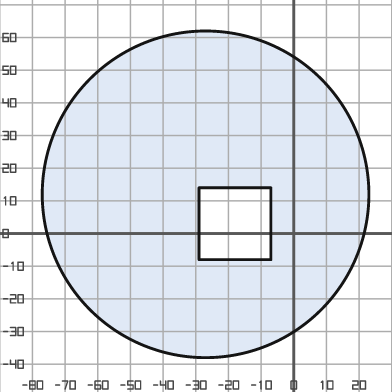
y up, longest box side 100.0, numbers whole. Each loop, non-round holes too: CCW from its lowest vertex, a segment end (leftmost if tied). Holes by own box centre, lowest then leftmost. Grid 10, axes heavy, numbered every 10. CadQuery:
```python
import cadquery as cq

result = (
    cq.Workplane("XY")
    .moveTo(-27.0, 12.0)
    .circle(50.0)
    .moveTo(-29.0, -8.0)
    .lineTo(-7.0, -8.0)
    .lineTo(-7.0, 14.0)
    .lineTo(-29.0, 14.0)
    .close()
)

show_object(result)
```